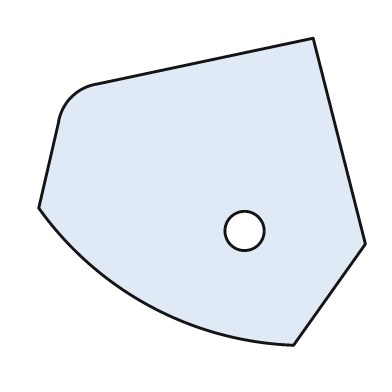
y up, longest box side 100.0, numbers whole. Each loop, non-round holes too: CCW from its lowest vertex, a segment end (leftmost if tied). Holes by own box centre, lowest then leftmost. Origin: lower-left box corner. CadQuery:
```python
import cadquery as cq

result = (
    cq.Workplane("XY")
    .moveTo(78.0, 0.0)
    .lineTo(100.0, 31.0)
    .lineTo(84.0, 94.0)
    .lineTo(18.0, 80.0)
    .threePointArc((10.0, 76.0), (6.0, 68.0))
    .lineTo(0.0, 42.0)
    .threePointArc((34.0, 12.0), (78.0, 0.0))
    .close()
    .moveTo(63.0, 35.0)
    .circle(6.0)
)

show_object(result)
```